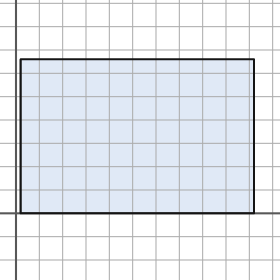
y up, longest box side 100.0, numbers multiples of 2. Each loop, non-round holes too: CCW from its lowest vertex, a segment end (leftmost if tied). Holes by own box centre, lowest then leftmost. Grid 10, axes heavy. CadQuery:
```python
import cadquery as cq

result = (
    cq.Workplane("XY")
    .moveTo(2.0, 0.0)
    .lineTo(102.0, 0.0)
    .lineTo(102.0, 66.0)
    .lineTo(2.0, 66.0)
    .close()
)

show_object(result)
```